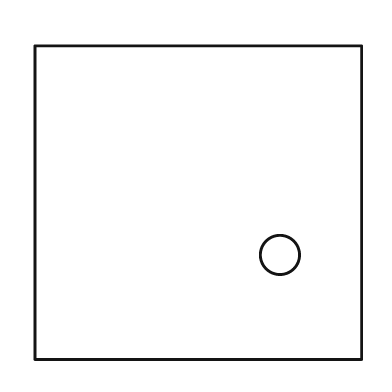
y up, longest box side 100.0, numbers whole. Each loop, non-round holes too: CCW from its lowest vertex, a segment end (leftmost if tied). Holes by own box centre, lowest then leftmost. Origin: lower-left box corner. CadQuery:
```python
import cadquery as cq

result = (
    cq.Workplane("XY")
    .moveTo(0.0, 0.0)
    .lineTo(100.0, 0.0)
    .lineTo(100.0, 96.0)
    .lineTo(0.0, 96.0)
    .close()
    .moveTo(75.0, 32.0)
    .circle(6.0)
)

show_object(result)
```